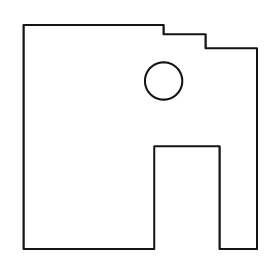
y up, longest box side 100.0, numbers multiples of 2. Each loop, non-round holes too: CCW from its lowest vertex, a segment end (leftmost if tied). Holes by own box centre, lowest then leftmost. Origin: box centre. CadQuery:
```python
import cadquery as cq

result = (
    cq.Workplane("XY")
    .moveTo(-50.0, -48.0)
    .lineTo(6.0, -48.0)
    .lineTo(6.0, -4.0)
    .lineTo(34.0, -4.0)
    .lineTo(34.0, -48.0)
    .lineTo(50.0, -48.0)
    .lineTo(50.0, 38.0)
    .lineTo(28.0, 38.0)
    .lineTo(28.0, 44.0)
    .lineTo(10.0, 44.0)
    .lineTo(10.0, 48.0)
    .lineTo(-50.0, 48.0)
    .close()
    .moveTo(10.0, 24.0)
    .circle(8.0)
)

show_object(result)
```